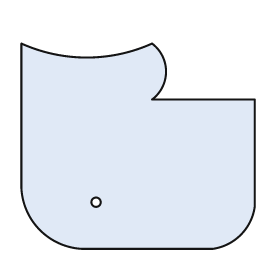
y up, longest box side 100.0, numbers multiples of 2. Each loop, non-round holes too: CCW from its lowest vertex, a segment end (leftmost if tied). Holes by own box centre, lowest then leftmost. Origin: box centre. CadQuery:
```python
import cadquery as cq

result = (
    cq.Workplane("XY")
    .moveTo(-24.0, -44.0)
    .lineTo(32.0, -44.0)
    .threePointArc((44.0, -38.0), (50.0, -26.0))
    .lineTo(50.0, 20.0)
    .lineTo(6.0, 20.0)
    .threePointArc((12.0, 32.0), (6.0, 44.0))
    .threePointArc((-22.0, 38.0), (-50.0, 44.0))
    .lineTo(-50.0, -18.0)
    .threePointArc((-42.0, -36.0), (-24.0, -44.0))
    .close()
    .moveTo(-18.0, -24.0)
    .circle(2.0)
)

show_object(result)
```